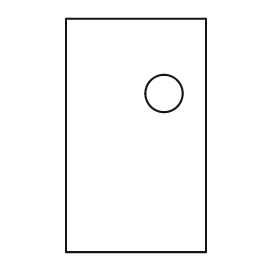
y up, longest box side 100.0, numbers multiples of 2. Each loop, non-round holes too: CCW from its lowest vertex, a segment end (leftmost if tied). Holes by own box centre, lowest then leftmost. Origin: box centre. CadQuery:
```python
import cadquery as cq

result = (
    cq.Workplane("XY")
    .moveTo(-30.0, -50.0)
    .lineTo(30.0, -50.0)
    .lineTo(30.0, 50.0)
    .lineTo(-30.0, 50.0)
    .close()
    .moveTo(12.0, 18.0)
    .circle(8.0)
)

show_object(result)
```